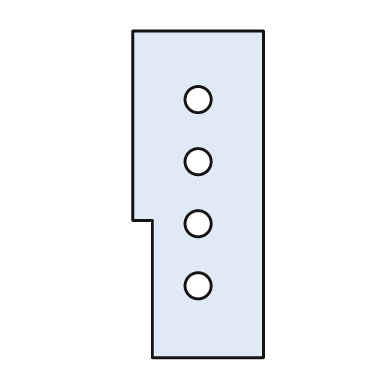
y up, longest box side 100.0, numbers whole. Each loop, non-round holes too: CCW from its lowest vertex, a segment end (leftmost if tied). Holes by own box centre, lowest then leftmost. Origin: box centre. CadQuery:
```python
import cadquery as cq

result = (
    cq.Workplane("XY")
    .moveTo(-14.0, -50.0)
    .lineTo(20.0, -50.0)
    .lineTo(20.0, 50.0)
    .lineTo(-20.0, 50.0)
    .lineTo(-20.0, -8.0)
    .lineTo(-14.0, -8.0)
    .close()
    .moveTo(0.0, -28.0)
    .circle(4.0)
    .moveTo(0.0, -9.0)
    .circle(4.0)
    .moveTo(0.0, 10.0)
    .circle(4.0)
    .moveTo(0.0, 29.0)
    .circle(4.0)
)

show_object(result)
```